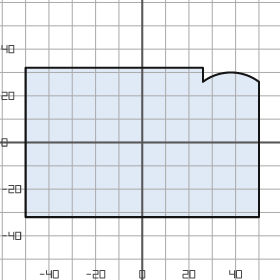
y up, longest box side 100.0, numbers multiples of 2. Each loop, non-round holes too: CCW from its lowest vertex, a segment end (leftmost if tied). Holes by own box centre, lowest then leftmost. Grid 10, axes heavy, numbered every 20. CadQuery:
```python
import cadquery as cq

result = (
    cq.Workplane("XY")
    .moveTo(-50.0, -32.0)
    .lineTo(50.0, -32.0)
    .lineTo(50.0, 26.0)
    .threePointArc((38.0, 30.0), (26.0, 26.0))
    .lineTo(26.0, 32.0)
    .lineTo(-50.0, 32.0)
    .close()
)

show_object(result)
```